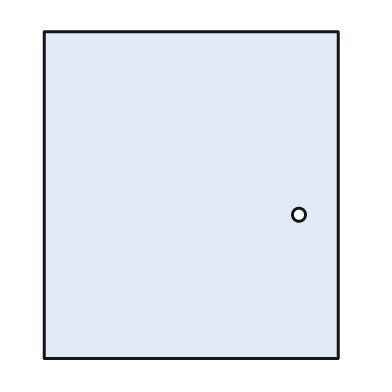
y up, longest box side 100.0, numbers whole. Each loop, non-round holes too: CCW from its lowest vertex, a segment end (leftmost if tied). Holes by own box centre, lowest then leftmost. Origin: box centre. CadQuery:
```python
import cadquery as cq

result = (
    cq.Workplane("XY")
    .moveTo(-45.0, -50.0)
    .lineTo(45.0, -50.0)
    .lineTo(45.0, 50.0)
    .lineTo(-45.0, 50.0)
    .close()
    .moveTo(33.0, -6.0)
    .circle(2.0)
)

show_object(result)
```